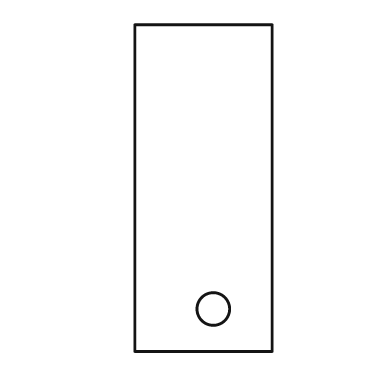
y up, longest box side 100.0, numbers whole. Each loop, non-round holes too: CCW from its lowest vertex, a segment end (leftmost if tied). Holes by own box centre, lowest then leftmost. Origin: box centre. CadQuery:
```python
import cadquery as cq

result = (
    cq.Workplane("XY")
    .moveTo(-21.0, -50.0)
    .lineTo(21.0, -50.0)
    .lineTo(21.0, 50.0)
    .lineTo(-21.0, 50.0)
    .close()
    .moveTo(3.0, -37.0)
    .circle(5.0)
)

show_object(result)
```